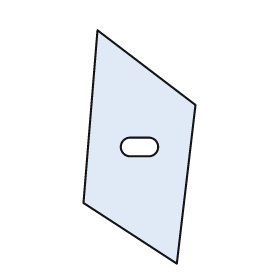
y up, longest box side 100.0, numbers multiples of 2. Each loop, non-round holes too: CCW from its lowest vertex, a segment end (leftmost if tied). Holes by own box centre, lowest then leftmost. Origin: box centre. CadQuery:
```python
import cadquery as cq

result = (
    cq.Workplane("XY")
    .moveTo(16.0, -50.0)
    .lineTo(24.0, 18.0)
    .lineTo(-18.0, 50.0)
    .lineTo(-24.0, -24.0)
    .close()
    .moveTo(-4.0, -4.0)
    .lineTo(4.0, -4.0)
    .threePointArc((8.0, 0.0), (4.0, 4.0))
    .lineTo(-4.0, 4.0)
    .threePointArc((-8.0, 0.0), (-4.0, -4.0))
    .close()
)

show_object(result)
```